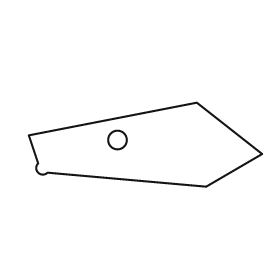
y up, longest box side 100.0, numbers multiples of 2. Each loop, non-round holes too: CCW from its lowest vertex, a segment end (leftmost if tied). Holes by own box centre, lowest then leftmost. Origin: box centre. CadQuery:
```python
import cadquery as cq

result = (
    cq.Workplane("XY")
    .moveTo(26.0, -18.0)
    .lineTo(50.0, -4.0)
    .lineTo(22.0, 18.0)
    .lineTo(-50.0, 4.0)
    .lineTo(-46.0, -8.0)
    .threePointArc((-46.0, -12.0), (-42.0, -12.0))
    .close()
    .moveTo(-12.0, 2.0)
    .circle(4.0)
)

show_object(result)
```